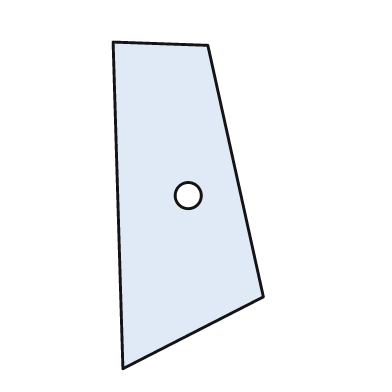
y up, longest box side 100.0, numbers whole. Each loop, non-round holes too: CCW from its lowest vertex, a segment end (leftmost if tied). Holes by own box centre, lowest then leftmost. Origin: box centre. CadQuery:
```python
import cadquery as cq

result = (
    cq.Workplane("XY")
    .moveTo(-20.0, -50.0)
    .lineTo(23.0, -28.0)
    .lineTo(6.0, 49.0)
    .lineTo(-23.0, 50.0)
    .close()
    .moveTo(0.0, 3.0)
    .circle(4.0)
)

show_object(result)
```